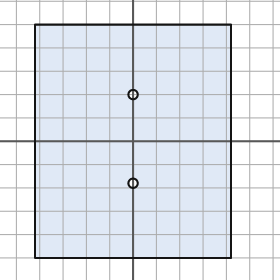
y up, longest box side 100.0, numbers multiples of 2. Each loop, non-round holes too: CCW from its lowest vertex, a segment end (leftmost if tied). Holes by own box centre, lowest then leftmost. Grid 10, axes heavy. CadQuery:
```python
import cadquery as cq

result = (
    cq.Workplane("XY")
    .moveTo(-42.0, -50.0)
    .lineTo(42.0, -50.0)
    .lineTo(42.0, 50.0)
    .lineTo(-42.0, 50.0)
    .close()
    .moveTo(0.0, -18.0)
    .circle(2.0)
    .moveTo(0.0, 20.0)
    .circle(2.0)
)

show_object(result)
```